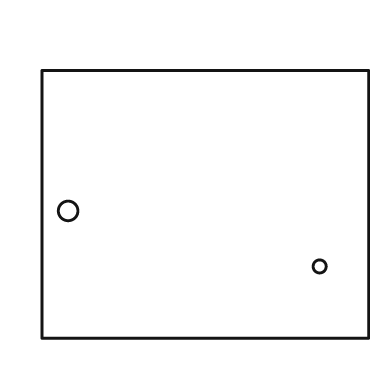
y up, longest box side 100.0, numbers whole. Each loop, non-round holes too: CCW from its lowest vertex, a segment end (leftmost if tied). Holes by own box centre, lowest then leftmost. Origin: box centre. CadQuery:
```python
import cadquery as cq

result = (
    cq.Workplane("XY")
    .moveTo(-50.0, -41.0)
    .lineTo(50.0, -41.0)
    .lineTo(50.0, 41.0)
    .lineTo(-50.0, 41.0)
    .close()
    .moveTo(35.0, -19.0)
    .circle(2.0)
    .moveTo(-42.0, -2.0)
    .circle(3.0)
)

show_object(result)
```